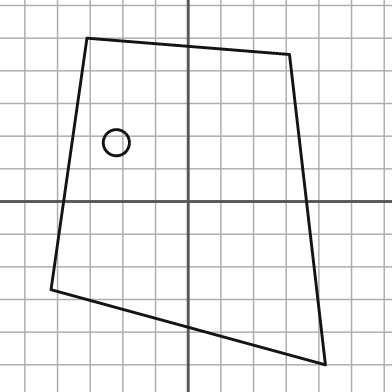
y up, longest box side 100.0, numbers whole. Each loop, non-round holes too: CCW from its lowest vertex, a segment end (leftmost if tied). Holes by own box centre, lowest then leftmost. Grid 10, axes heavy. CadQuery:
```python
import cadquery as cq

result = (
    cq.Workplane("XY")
    .moveTo(42.0, -50.0)
    .lineTo(31.0, 45.0)
    .lineTo(-31.0, 50.0)
    .lineTo(-42.0, -27.0)
    .close()
    .moveTo(-22.0, 18.0)
    .circle(4.0)
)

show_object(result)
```